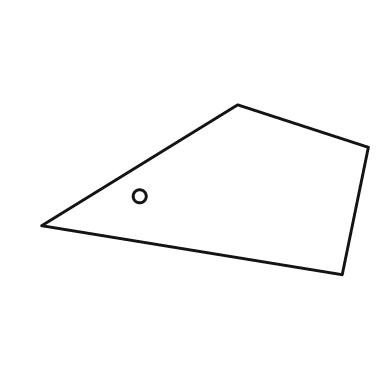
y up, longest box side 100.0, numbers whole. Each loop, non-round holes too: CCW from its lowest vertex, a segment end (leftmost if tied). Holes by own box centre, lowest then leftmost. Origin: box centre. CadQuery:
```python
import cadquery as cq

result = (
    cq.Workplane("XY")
    .moveTo(42.0, -26.0)
    .lineTo(50.0, 13.0)
    .lineTo(10.0, 26.0)
    .lineTo(-50.0, -11.0)
    .close()
    .moveTo(-20.0, -2.0)
    .circle(2.0)
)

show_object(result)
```